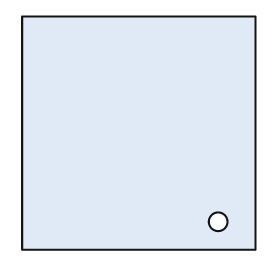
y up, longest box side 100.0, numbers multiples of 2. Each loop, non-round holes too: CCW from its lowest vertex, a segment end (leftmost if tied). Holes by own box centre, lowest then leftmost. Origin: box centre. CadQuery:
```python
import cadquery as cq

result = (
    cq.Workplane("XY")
    .moveTo(-50.0, -50.0)
    .lineTo(50.0, -50.0)
    .lineTo(50.0, 50.0)
    .lineTo(-50.0, 50.0)
    .close()
    .moveTo(34.0, -38.0)
    .circle(4.0)
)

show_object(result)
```